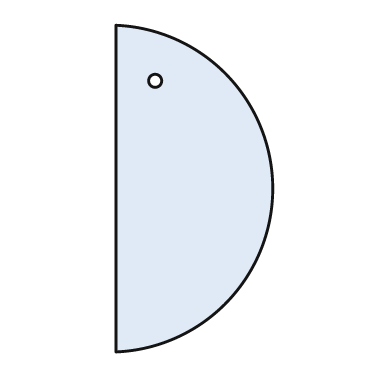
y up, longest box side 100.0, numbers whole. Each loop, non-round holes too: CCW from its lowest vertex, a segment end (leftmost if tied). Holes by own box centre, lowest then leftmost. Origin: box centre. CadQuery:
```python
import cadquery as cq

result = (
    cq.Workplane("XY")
    .moveTo(-24.0, -50.0)
    .threePointArc((24.0, 0.0), (-24.0, 50.0))
    .close()
    .moveTo(-12.0, 33.0)
    .circle(2.0)
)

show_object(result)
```